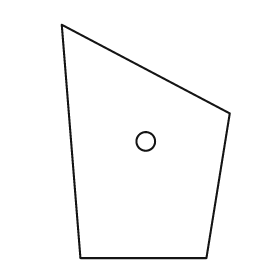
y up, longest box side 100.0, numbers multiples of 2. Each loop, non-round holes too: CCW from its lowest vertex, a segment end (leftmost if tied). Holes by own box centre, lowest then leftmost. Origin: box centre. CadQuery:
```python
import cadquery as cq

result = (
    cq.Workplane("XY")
    .moveTo(-28.0, -50.0)
    .lineTo(26.0, -50.0)
    .lineTo(36.0, 12.0)
    .lineTo(-36.0, 50.0)
    .close()
    .moveTo(0.0, 0.0)
    .circle(4.0)
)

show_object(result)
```